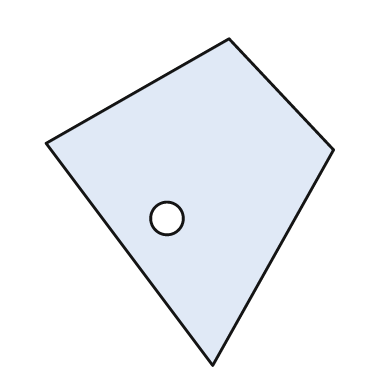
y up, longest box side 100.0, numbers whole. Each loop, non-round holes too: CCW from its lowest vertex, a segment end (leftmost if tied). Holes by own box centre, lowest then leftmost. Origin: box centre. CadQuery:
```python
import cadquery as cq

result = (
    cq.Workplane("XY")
    .moveTo(7.0, -50.0)
    .lineTo(44.0, 16.0)
    .lineTo(12.0, 50.0)
    .lineTo(-44.0, 18.0)
    .close()
    .moveTo(-7.0, -5.0)
    .circle(5.0)
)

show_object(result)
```